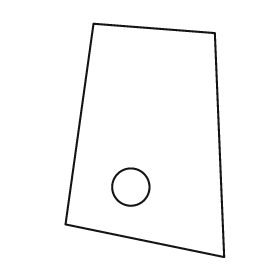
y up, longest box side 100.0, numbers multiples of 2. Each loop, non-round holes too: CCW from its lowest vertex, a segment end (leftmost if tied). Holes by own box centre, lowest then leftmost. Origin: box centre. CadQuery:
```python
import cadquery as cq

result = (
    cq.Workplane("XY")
    .moveTo(34.0, -50.0)
    .lineTo(30.0, 46.0)
    .lineTo(-22.0, 50.0)
    .lineTo(-34.0, -36.0)
    .close()
    .moveTo(-6.0, -20.0)
    .circle(8.0)
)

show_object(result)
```